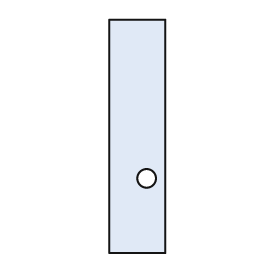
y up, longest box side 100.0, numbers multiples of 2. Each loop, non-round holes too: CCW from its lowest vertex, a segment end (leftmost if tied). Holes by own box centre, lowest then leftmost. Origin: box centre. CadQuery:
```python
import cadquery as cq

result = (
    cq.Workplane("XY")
    .moveTo(-12.0, -50.0)
    .lineTo(12.0, -50.0)
    .lineTo(12.0, 50.0)
    .lineTo(-12.0, 50.0)
    .close()
    .moveTo(4.0, -18.0)
    .circle(4.0)
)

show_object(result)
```